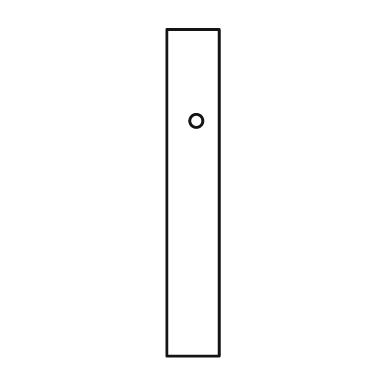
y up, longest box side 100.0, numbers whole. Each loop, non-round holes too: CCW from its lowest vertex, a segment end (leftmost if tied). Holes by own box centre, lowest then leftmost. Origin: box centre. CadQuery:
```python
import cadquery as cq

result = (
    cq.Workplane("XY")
    .moveTo(-8.0, -50.0)
    .lineTo(8.0, -50.0)
    .lineTo(8.0, 50.0)
    .lineTo(-8.0, 50.0)
    .close()
    .moveTo(1.0, 22.0)
    .circle(2.0)
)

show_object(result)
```